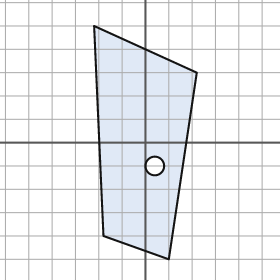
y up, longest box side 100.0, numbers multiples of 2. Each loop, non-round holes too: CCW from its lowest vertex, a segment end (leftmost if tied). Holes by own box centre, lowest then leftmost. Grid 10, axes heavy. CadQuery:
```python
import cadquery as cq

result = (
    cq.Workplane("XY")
    .moveTo(10.0, -50.0)
    .lineTo(22.0, 30.0)
    .lineTo(-22.0, 50.0)
    .lineTo(-18.0, -40.0)
    .close()
    .moveTo(4.0, -10.0)
    .circle(4.0)
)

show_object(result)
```